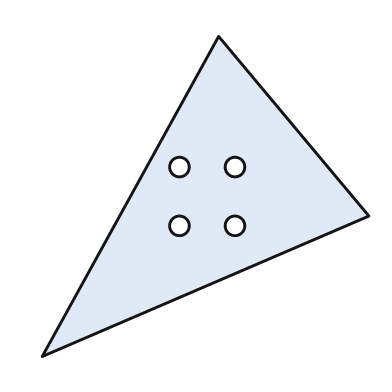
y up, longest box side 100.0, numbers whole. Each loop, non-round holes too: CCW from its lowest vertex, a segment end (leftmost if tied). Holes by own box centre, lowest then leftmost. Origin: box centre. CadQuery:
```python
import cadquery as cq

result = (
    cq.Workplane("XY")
    .moveTo(-50.0, -49.0)
    .lineTo(50.0, -6.0)
    .lineTo(4.0, 49.0)
    .close()
    .moveTo(-8.0, -9.0)
    .circle(3.0)
    .moveTo(9.0, -9.0)
    .circle(3.0)
    .moveTo(-8.0, 9.0)
    .circle(3.0)
    .moveTo(9.0, 9.0)
    .circle(3.0)
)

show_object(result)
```